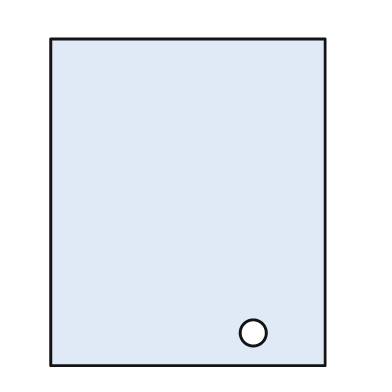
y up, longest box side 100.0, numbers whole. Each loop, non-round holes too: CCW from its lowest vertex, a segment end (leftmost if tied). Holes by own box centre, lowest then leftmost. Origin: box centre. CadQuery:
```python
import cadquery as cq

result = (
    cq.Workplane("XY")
    .moveTo(-42.0, -50.0)
    .lineTo(42.0, -50.0)
    .lineTo(42.0, 50.0)
    .lineTo(-42.0, 50.0)
    .close()
    .moveTo(20.0, -40.0)
    .circle(4.0)
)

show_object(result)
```